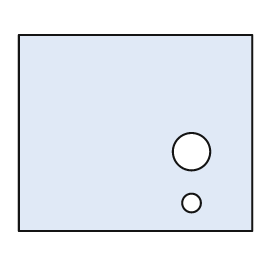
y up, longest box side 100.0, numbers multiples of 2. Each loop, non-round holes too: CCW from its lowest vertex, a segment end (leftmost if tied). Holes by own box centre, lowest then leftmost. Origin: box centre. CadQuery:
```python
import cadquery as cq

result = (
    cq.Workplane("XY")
    .moveTo(-50.0, -42.0)
    .lineTo(50.0, -42.0)
    .lineTo(50.0, 42.0)
    .lineTo(-50.0, 42.0)
    .close()
    .moveTo(24.0, -30.0)
    .circle(4.0)
    .moveTo(24.0, -8.0)
    .circle(8.0)
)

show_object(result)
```